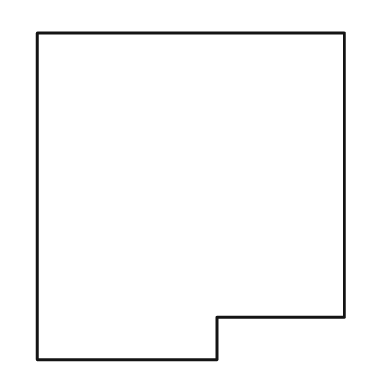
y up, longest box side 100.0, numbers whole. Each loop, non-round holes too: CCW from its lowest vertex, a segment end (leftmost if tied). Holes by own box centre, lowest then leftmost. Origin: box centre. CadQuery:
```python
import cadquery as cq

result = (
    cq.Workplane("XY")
    .moveTo(-47.0, -50.0)
    .lineTo(8.0, -50.0)
    .lineTo(8.0, -37.0)
    .lineTo(47.0, -37.0)
    .lineTo(47.0, 50.0)
    .lineTo(-47.0, 50.0)
    .close()
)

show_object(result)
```